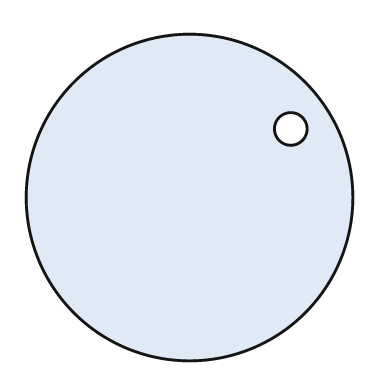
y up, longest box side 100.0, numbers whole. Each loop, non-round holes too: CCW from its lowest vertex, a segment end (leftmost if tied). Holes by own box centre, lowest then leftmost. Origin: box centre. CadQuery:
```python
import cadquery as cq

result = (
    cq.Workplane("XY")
    .moveTo(0.0, 0.0)
    .circle(50.0)
    .moveTo(31.0, 21.0)
    .circle(5.0)
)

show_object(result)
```